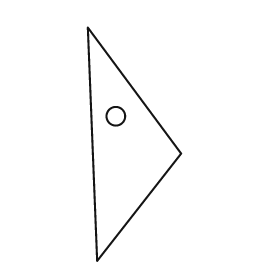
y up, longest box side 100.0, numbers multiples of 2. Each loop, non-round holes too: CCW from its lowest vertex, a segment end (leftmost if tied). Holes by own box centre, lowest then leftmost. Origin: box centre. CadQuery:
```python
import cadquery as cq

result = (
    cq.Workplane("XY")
    .moveTo(-16.0, -50.0)
    .lineTo(20.0, -4.0)
    .lineTo(-20.0, 50.0)
    .close()
    .moveTo(-8.0, 12.0)
    .circle(4.0)
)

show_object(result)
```